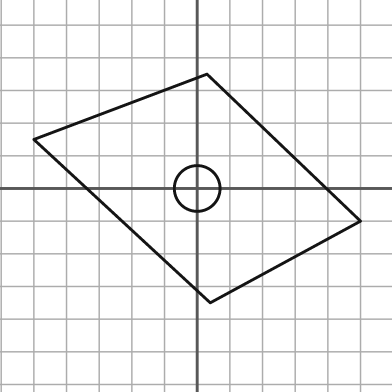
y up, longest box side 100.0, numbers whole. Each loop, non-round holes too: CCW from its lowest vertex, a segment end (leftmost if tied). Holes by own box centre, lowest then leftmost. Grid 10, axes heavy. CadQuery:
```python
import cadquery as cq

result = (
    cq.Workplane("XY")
    .moveTo(4.0, -35.0)
    .lineTo(50.0, -10.0)
    .lineTo(3.0, 35.0)
    .lineTo(-50.0, 15.0)
    .close()
    .moveTo(0.0, 0.0)
    .circle(7.0)
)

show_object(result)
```